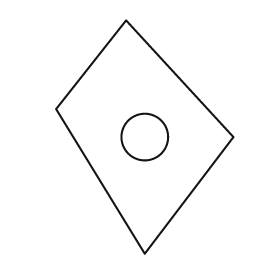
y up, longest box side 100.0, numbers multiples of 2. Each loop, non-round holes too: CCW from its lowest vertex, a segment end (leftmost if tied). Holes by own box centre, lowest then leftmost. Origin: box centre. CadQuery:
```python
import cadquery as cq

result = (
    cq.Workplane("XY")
    .moveTo(0.0, -50.0)
    .lineTo(38.0, 0.0)
    .lineTo(-8.0, 50.0)
    .lineTo(-38.0, 12.0)
    .close()
    .moveTo(0.0, 0.0)
    .circle(10.0)
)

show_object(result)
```